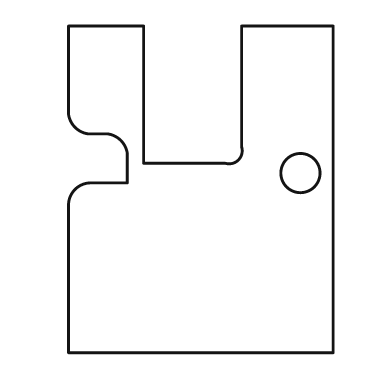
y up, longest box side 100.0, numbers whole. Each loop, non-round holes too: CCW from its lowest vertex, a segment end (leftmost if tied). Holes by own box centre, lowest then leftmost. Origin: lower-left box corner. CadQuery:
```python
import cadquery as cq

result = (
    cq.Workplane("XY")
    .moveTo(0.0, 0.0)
    .lineTo(81.0, 0.0)
    .lineTo(81.0, 100.0)
    .lineTo(53.0, 100.0)
    .lineTo(53.0, 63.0)
    .threePointArc((52.0, 59.0), (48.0, 58.0))
    .lineTo(23.0, 58.0)
    .lineTo(23.0, 100.0)
    .lineTo(0.0, 100.0)
    .lineTo(0.0, 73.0)
    .threePointArc((2.0, 69.0), (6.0, 67.0))
    .lineTo(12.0, 67.0)
    .threePointArc((16.0, 65.0), (18.0, 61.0))
    .lineTo(18.0, 52.0)
    .lineTo(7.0, 52.0)
    .threePointArc((2.0, 50.0), (0.0, 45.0))
    .close()
    .moveTo(71.0, 55.0)
    .circle(6.0)
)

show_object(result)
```